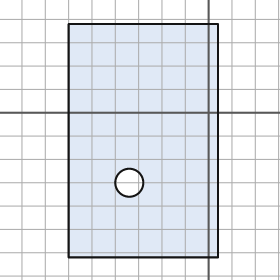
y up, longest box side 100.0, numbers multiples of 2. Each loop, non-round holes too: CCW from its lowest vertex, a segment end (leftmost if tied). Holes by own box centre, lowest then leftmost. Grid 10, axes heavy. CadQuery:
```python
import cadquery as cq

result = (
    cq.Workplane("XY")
    .moveTo(-60.0, -62.0)
    .lineTo(4.0, -62.0)
    .lineTo(4.0, 38.0)
    .lineTo(-60.0, 38.0)
    .close()
    .moveTo(-34.0, -30.0)
    .circle(6.0)
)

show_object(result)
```